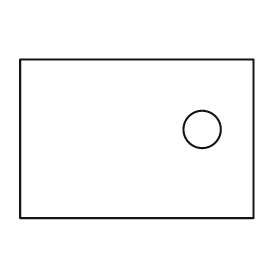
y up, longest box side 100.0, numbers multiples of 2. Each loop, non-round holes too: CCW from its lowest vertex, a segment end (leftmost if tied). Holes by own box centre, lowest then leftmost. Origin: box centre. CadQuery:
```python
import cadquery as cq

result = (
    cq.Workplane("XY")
    .moveTo(-50.0, -34.0)
    .lineTo(50.0, -34.0)
    .lineTo(50.0, 34.0)
    .lineTo(-50.0, 34.0)
    .close()
    .moveTo(28.0, 4.0)
    .circle(8.0)
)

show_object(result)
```